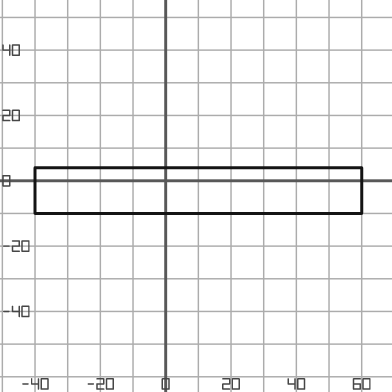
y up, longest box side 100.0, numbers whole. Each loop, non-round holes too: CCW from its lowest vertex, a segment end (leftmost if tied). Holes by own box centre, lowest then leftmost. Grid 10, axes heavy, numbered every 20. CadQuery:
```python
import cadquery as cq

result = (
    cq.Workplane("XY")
    .moveTo(-40.0, -10.0)
    .lineTo(60.0, -10.0)
    .lineTo(60.0, 4.0)
    .lineTo(-40.0, 4.0)
    .close()
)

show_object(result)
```